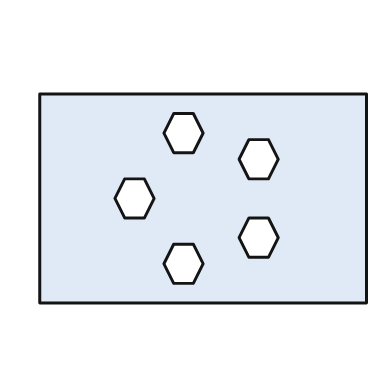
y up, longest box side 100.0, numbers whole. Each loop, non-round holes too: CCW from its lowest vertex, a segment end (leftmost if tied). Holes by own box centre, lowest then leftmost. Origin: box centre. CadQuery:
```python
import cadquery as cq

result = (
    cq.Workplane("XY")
    .moveTo(-50.0, -32.0)
    .lineTo(50.0, -32.0)
    .lineTo(50.0, 32.0)
    .lineTo(-50.0, 32.0)
    .close()
    .moveTo(-9.0, -26.0)
    .lineTo(-3.0, -26.0)
    .lineTo(0.0, -20.0)
    .lineTo(-3.0, -14.0)
    .lineTo(-9.0, -14.0)
    .lineTo(-12.0, -20.0)
    .close()
    .moveTo(14.0, -18.0)
    .lineTo(20.0, -18.0)
    .lineTo(23.0, -12.0)
    .lineTo(20.0, -6.0)
    .lineTo(14.0, -6.0)
    .lineTo(11.0, -12.0)
    .close()
    .moveTo(-24.0, -6.0)
    .lineTo(-18.0, -6.0)
    .lineTo(-15.0, 0.0)
    .lineTo(-18.0, 6.0)
    .lineTo(-24.0, 6.0)
    .lineTo(-27.0, 0.0)
    .close()
    .moveTo(14.0, 6.0)
    .lineTo(20.0, 6.0)
    .lineTo(23.0, 12.0)
    .lineTo(20.0, 18.0)
    .lineTo(14.0, 18.0)
    .lineTo(11.0, 12.0)
    .close()
    .moveTo(-9.0, 14.0)
    .lineTo(-3.0, 14.0)
    .lineTo(0.0, 20.0)
    .lineTo(-3.0, 26.0)
    .lineTo(-9.0, 26.0)
    .lineTo(-12.0, 20.0)
    .close()
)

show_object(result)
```